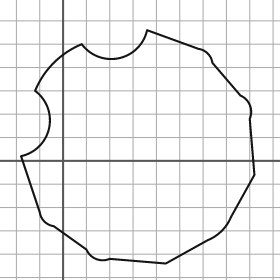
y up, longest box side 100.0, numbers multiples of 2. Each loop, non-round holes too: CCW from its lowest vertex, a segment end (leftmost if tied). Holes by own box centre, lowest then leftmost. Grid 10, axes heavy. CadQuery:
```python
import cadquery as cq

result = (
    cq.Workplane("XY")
    .moveTo(44.0, -44.0)
    .lineTo(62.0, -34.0)
    .threePointArc((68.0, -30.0), (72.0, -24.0))
    .lineTo(82.0, -6.0)
    .lineTo(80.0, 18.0)
    .threePointArc((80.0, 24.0), (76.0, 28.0))
    .lineTo(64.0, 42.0)
    .threePointArc((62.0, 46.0), (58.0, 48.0))
    .lineTo(36.0, 56.0)
    .threePointArc((24.0, 44.0), (8.0, 50.0))
    .threePointArc((-4.0, 42.0), (-12.0, 30.0))
    .threePointArc((-6.0, 14.0), (-18.0, 2.0))
    .lineTo(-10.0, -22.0)
    .threePointArc((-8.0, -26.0), (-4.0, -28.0))
    .lineTo(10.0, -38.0)
    .threePointArc((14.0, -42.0), (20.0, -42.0))
    .close()
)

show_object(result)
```